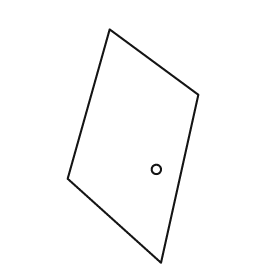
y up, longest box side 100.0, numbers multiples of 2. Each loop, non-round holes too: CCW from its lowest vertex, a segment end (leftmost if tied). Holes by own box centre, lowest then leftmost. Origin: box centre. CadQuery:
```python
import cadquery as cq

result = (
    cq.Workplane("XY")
    .moveTo(12.0, -50.0)
    .lineTo(28.0, 22.0)
    .lineTo(-10.0, 50.0)
    .lineTo(-28.0, -14.0)
    .close()
    .moveTo(10.0, -10.0)
    .circle(2.0)
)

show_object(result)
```